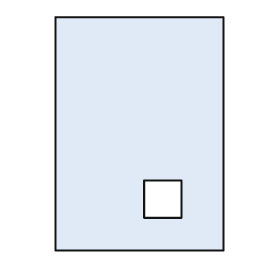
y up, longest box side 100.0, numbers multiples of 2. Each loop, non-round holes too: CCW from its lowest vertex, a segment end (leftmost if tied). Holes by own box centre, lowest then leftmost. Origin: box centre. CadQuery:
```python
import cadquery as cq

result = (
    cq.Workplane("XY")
    .moveTo(-36.0, -50.0)
    .lineTo(36.0, -50.0)
    .lineTo(36.0, 50.0)
    .lineTo(-36.0, 50.0)
    .close()
    .moveTo(2.0, -36.0)
    .lineTo(18.0, -36.0)
    .lineTo(18.0, -20.0)
    .lineTo(2.0, -20.0)
    .close()
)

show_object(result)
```